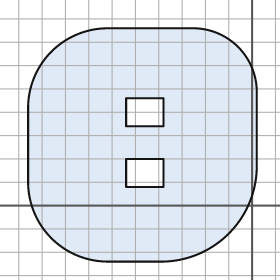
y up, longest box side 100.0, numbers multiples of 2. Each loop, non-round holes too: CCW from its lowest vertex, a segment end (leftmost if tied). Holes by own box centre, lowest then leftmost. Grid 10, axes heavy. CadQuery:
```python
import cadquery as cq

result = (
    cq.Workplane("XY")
    .moveTo(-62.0, -24.0)
    .lineTo(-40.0, -24.0)
    .threePointArc((-10.0, -12.0), (2.0, 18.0))
    .lineTo(2.0, 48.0)
    .threePointArc((-6.0, 68.0), (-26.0, 76.0))
    .lineTo(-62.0, 76.0)
    .threePointArc((-86.0, 66.0), (-96.0, 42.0))
    .lineTo(-96.0, 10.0)
    .threePointArc((-86.0, -14.0), (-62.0, -24.0))
    .close()
    .moveTo(-54.0, 8.0)
    .lineTo(-38.0, 8.0)
    .lineTo(-38.0, 20.0)
    .lineTo(-54.0, 20.0)
    .close()
    .moveTo(-54.0, 34.0)
    .lineTo(-38.0, 34.0)
    .lineTo(-38.0, 46.0)
    .lineTo(-54.0, 46.0)
    .close()
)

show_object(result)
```